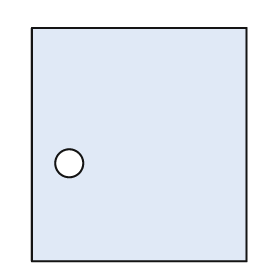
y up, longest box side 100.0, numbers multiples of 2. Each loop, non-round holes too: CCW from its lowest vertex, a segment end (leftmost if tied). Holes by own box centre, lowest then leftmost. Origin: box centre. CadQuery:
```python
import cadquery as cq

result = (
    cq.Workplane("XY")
    .moveTo(-46.0, -50.0)
    .lineTo(46.0, -50.0)
    .lineTo(46.0, 50.0)
    .lineTo(-46.0, 50.0)
    .close()
    .moveTo(-30.0, -8.0)
    .circle(6.0)
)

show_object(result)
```